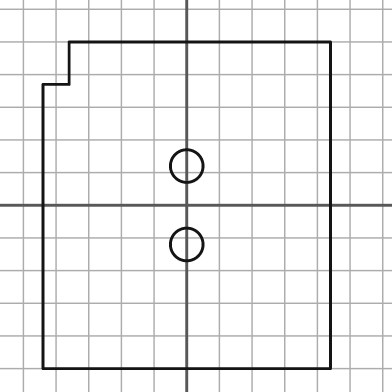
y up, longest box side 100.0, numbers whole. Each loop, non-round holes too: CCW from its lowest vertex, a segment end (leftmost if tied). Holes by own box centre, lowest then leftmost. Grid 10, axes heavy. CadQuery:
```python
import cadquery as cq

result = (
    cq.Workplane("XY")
    .moveTo(-44.0, -50.0)
    .lineTo(44.0, -50.0)
    .lineTo(44.0, 50.0)
    .lineTo(-36.0, 50.0)
    .lineTo(-36.0, 37.0)
    .lineTo(-44.0, 37.0)
    .close()
    .moveTo(0.0, -12.0)
    .circle(5.0)
    .moveTo(0.0, 12.0)
    .circle(5.0)
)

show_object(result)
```